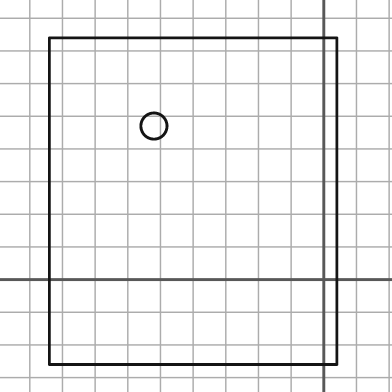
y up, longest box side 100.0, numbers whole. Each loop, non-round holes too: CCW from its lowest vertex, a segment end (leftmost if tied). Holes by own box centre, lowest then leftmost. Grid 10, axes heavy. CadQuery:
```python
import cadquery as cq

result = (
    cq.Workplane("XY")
    .moveTo(-84.0, -26.0)
    .lineTo(4.0, -26.0)
    .lineTo(4.0, 74.0)
    .lineTo(-84.0, 74.0)
    .close()
    .moveTo(-52.0, 47.0)
    .circle(4.0)
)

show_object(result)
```